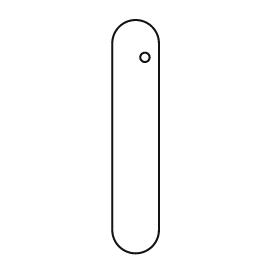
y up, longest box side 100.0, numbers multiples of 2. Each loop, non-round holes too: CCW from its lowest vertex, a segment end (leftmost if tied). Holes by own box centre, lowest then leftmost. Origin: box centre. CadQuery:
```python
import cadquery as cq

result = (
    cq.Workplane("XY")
    .moveTo(-10.0, -40.0)
    .threePointArc((0.0, -50.0), (10.0, -40.0))
    .lineTo(10.0, 40.0)
    .threePointArc((0.0, 50.0), (-10.0, 40.0))
    .close()
    .moveTo(4.0, 34.0)
    .circle(2.0)
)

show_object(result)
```